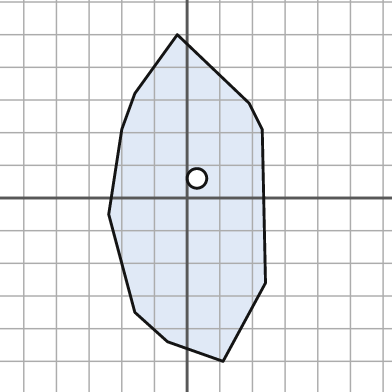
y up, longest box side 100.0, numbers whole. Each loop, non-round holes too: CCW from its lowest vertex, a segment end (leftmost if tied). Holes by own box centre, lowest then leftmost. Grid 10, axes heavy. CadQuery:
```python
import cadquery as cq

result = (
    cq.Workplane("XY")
    .moveTo(11.0, -50.0)
    .lineTo(24.0, -26.0)
    .lineTo(23.0, 21.0)
    .lineTo(19.0, 29.0)
    .lineTo(-3.0, 50.0)
    .lineTo(-16.0, 32.0)
    .lineTo(-20.0, 21.0)
    .lineTo(-24.0, -5.0)
    .lineTo(-16.0, -35.0)
    .lineTo(-6.0, -44.0)
    .close()
    .moveTo(3.0, 6.0)
    .circle(3.0)
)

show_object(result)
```